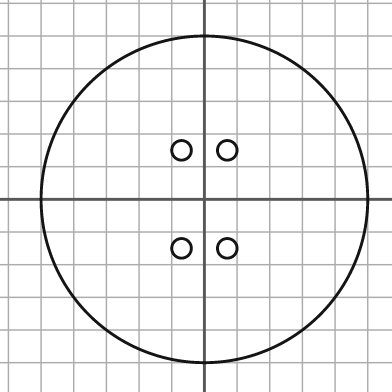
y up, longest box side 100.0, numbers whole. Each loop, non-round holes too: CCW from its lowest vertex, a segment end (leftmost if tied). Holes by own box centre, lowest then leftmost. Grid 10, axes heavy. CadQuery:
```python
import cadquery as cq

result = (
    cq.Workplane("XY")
    .moveTo(0.0, 0.0)
    .circle(50.0)
    .moveTo(-7.0, -15.0)
    .circle(3.0)
    .moveTo(7.0, -15.0)
    .circle(3.0)
    .moveTo(-7.0, 15.0)
    .circle(3.0)
    .moveTo(7.0, 15.0)
    .circle(3.0)
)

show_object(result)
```